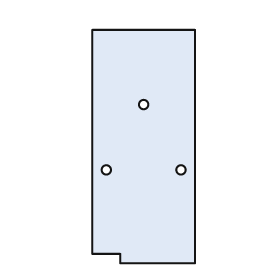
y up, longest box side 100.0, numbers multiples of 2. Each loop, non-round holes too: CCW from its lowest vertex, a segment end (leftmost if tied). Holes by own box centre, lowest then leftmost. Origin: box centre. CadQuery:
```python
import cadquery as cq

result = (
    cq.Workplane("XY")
    .moveTo(-10.0, -50.0)
    .lineTo(22.0, -50.0)
    .lineTo(22.0, 50.0)
    .lineTo(-22.0, 50.0)
    .lineTo(-22.0, -46.0)
    .lineTo(-10.0, -46.0)
    .close()
    .moveTo(-16.0, -10.0)
    .circle(2.0)
    .moveTo(16.0, -10.0)
    .circle(2.0)
    .moveTo(0.0, 18.0)
    .circle(2.0)
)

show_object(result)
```